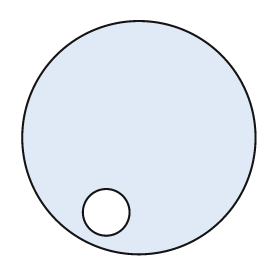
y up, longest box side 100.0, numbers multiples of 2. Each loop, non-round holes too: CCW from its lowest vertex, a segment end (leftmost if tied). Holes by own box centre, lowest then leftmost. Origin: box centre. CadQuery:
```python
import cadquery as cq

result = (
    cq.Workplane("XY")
    .moveTo(0.0, 0.0)
    .circle(50.0)
    .moveTo(-14.0, -32.0)
    .circle(10.0)
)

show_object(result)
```